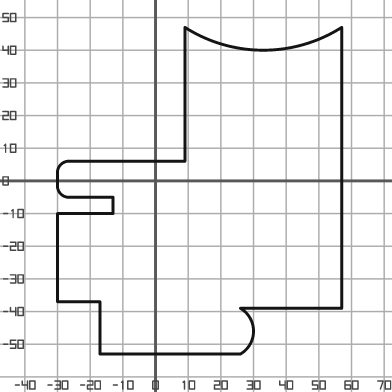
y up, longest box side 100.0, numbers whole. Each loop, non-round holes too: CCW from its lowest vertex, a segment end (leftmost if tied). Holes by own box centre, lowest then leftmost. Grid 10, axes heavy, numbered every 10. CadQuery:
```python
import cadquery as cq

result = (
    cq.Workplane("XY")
    .moveTo(-17.0, -53.0)
    .lineTo(26.0, -53.0)
    .threePointArc((30.0, -46.0), (26.0, -39.0))
    .lineTo(57.0, -39.0)
    .lineTo(57.0, 47.0)
    .threePointArc((33.0, 40.0), (9.0, 47.0))
    .lineTo(9.0, 6.0)
    .lineTo(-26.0, 6.0)
    .threePointArc((-29.0, 5.0), (-30.0, 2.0))
    .lineTo(-30.0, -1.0)
    .threePointArc((-29.0, -4.0), (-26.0, -5.0))
    .lineTo(-13.0, -5.0)
    .lineTo(-13.0, -10.0)
    .lineTo(-30.0, -10.0)
    .lineTo(-30.0, -37.0)
    .lineTo(-17.0, -37.0)
    .close()
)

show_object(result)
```